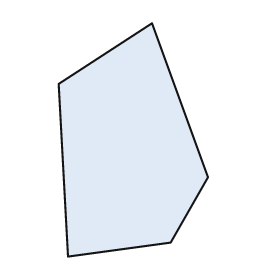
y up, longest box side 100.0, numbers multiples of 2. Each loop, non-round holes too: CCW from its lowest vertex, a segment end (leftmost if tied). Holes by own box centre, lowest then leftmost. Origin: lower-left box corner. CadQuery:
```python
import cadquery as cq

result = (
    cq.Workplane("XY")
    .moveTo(4.0, 0.0)
    .lineTo(48.0, 6.0)
    .lineTo(64.0, 34.0)
    .lineTo(40.0, 100.0)
    .lineTo(0.0, 74.0)
    .close()
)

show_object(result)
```